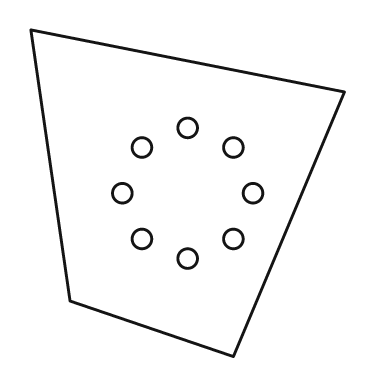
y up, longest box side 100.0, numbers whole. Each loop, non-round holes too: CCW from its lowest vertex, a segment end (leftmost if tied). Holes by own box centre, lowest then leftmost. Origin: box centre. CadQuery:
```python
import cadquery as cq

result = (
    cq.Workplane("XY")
    .moveTo(14.0, -50.0)
    .lineTo(48.0, 31.0)
    .lineTo(-48.0, 50.0)
    .lineTo(-36.0, -33.0)
    .close()
    .moveTo(0.0, -20.0)
    .circle(3.0)
    .moveTo(-14.0, -14.0)
    .circle(3.0)
    .moveTo(14.0, -14.0)
    .circle(3.0)
    .moveTo(-20.0, 0.0)
    .circle(3.0)
    .moveTo(20.0, 0.0)
    .circle(3.0)
    .moveTo(-14.0, 14.0)
    .circle(3.0)
    .moveTo(14.0, 14.0)
    .circle(3.0)
    .moveTo(0.0, 20.0)
    .circle(3.0)
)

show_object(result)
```